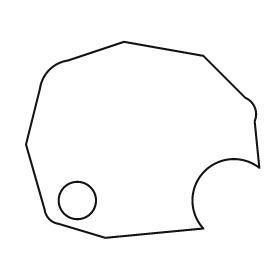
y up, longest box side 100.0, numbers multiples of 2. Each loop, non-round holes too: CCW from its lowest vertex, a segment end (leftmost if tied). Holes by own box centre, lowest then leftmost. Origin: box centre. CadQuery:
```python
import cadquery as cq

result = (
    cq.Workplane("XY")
    .moveTo(-16.0, -42.0)
    .lineTo(26.0, -38.0)
    .threePointArc((26.0, -14.0), (50.0, -12.0))
    .lineTo(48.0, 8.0)
    .threePointArc((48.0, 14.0), (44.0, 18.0))
    .lineTo(26.0, 36.0)
    .lineTo(-8.0, 42.0)
    .lineTo(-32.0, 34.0)
    .threePointArc((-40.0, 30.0), (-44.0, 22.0))
    .lineTo(-50.0, -2.0)
    .lineTo(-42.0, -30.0)
    .threePointArc((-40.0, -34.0), (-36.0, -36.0))
    .close()
    .moveTo(-28.0, -26.0)
    .circle(8.0)
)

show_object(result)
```